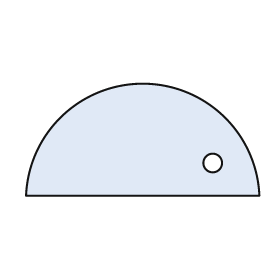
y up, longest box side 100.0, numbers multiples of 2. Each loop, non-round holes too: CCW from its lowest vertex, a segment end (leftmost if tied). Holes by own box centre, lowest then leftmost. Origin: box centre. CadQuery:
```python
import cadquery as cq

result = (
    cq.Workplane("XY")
    .moveTo(-50.0, -24.0)
    .lineTo(50.0, -24.0)
    .threePointArc((0.0, 24.0), (-50.0, -24.0))
    .close()
    .moveTo(30.0, -10.0)
    .circle(4.0)
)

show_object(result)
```